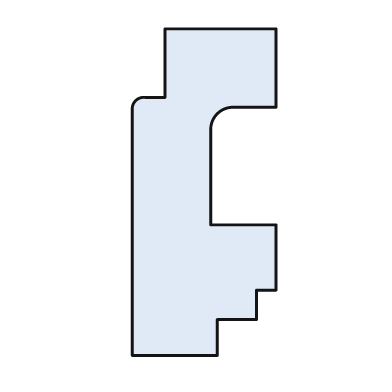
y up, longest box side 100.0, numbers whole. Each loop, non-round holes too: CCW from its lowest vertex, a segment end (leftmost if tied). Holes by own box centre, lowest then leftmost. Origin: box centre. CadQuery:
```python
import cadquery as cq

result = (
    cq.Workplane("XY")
    .moveTo(-22.0, -50.0)
    .lineTo(4.0, -50.0)
    .lineTo(4.0, -39.0)
    .lineTo(16.0, -39.0)
    .lineTo(16.0, -30.0)
    .lineTo(22.0, -30.0)
    .lineTo(22.0, -10.0)
    .lineTo(2.0, -10.0)
    .lineTo(2.0, 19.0)
    .threePointArc((4.0, 24.0), (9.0, 26.0))
    .lineTo(22.0, 26.0)
    .lineTo(22.0, 50.0)
    .lineTo(-12.0, 50.0)
    .lineTo(-12.0, 29.0)
    .lineTo(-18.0, 29.0)
    .threePointArc((-21.0, 28.0), (-22.0, 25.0))
    .close()
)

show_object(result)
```